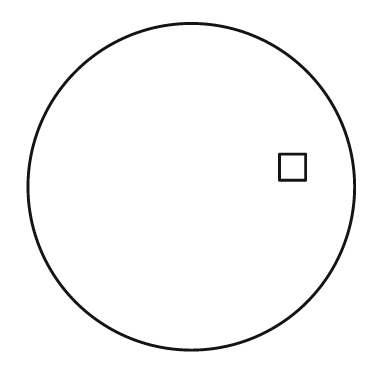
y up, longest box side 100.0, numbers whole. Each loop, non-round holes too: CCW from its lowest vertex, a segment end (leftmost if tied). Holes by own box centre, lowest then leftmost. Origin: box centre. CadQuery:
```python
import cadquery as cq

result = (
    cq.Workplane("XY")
    .moveTo(0.0, 0.0)
    .circle(50.0)
    .moveTo(27.0, 2.0)
    .lineTo(35.0, 2.0)
    .lineTo(35.0, 10.0)
    .lineTo(27.0, 10.0)
    .close()
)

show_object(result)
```